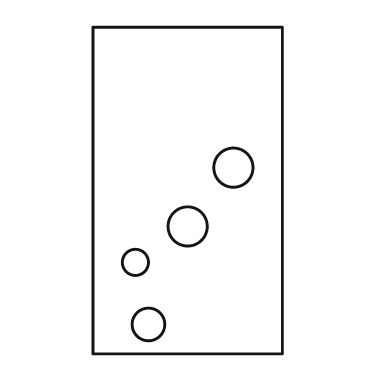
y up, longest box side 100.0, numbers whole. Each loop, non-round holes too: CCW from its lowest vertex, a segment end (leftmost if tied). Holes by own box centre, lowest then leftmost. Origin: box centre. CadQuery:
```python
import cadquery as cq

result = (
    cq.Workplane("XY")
    .moveTo(-29.0, -50.0)
    .lineTo(29.0, -50.0)
    .lineTo(29.0, 50.0)
    .lineTo(-29.0, 50.0)
    .close()
    .moveTo(-12.0, -41.0)
    .circle(5.0)
    .moveTo(-16.0, -22.0)
    .circle(4.0)
    .moveTo(0.0, -11.0)
    .circle(6.0)
    .moveTo(14.0, 7.0)
    .circle(6.0)
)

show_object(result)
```